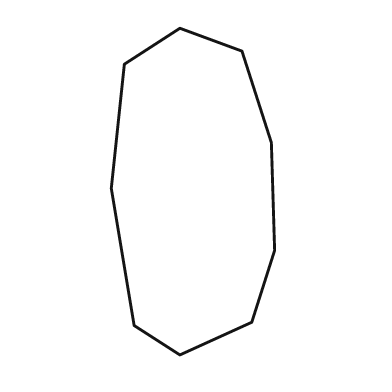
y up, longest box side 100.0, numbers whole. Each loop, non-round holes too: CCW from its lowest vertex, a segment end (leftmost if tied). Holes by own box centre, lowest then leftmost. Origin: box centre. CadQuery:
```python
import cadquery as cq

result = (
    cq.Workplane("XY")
    .moveTo(-4.0, -50.0)
    .lineTo(18.0, -40.0)
    .lineTo(25.0, -18.0)
    .lineTo(24.0, 15.0)
    .lineTo(15.0, 43.0)
    .lineTo(-4.0, 50.0)
    .lineTo(-21.0, 39.0)
    .lineTo(-25.0, 1.0)
    .lineTo(-18.0, -41.0)
    .close()
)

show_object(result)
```